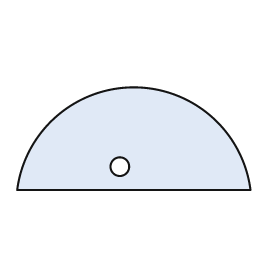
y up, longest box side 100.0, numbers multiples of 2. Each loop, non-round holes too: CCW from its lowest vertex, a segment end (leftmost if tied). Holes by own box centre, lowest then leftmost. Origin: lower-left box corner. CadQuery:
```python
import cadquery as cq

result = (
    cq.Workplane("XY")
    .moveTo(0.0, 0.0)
    .lineTo(100.0, 0.0)
    .threePointArc((50.0, 44.0), (0.0, 0.0))
    .close()
    .moveTo(44.0, 10.0)
    .circle(4.0)
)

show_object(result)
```